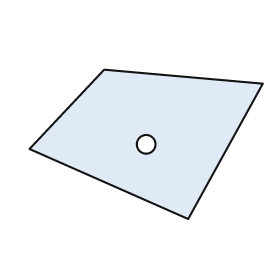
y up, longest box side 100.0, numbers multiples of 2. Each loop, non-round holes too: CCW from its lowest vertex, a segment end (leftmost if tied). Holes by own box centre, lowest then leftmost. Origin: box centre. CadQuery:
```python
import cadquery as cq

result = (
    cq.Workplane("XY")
    .moveTo(18.0, -32.0)
    .lineTo(50.0, 26.0)
    .lineTo(-18.0, 32.0)
    .lineTo(-50.0, -2.0)
    .close()
    .moveTo(0.0, 0.0)
    .circle(4.0)
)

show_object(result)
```